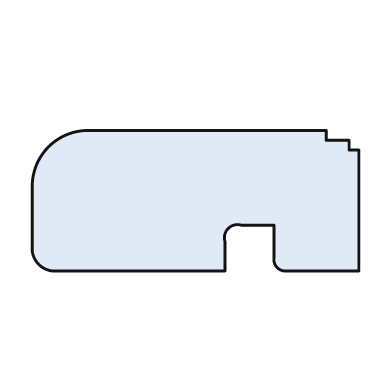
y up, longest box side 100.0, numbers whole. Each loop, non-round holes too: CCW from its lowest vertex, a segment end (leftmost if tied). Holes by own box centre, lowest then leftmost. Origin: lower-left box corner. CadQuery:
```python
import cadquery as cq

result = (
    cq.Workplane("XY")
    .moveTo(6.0, 0.0)
    .lineTo(59.0, 0.0)
    .lineTo(59.0, 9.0)
    .threePointArc((60.0, 13.0), (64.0, 14.0))
    .lineTo(74.0, 14.0)
    .lineTo(74.0, 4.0)
    .threePointArc((75.0, 1.0), (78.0, 0.0))
    .lineTo(100.0, 0.0)
    .lineTo(100.0, 37.0)
    .lineTo(97.0, 37.0)
    .lineTo(97.0, 40.0)
    .lineTo(90.0, 40.0)
    .lineTo(90.0, 43.0)
    .lineTo(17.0, 43.0)
    .threePointArc((5.0, 38.0), (0.0, 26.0))
    .lineTo(0.0, 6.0)
    .threePointArc((2.0, 2.0), (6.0, 0.0))
    .close()
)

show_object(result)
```